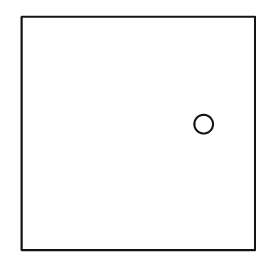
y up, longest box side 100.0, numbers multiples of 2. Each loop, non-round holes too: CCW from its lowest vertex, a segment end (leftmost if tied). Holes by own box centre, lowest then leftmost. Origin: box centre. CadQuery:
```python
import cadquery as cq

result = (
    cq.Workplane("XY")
    .moveTo(-50.0, -50.0)
    .lineTo(50.0, -50.0)
    .lineTo(50.0, 50.0)
    .lineTo(-50.0, 50.0)
    .close()
    .moveTo(28.0, 4.0)
    .circle(4.0)
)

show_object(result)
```